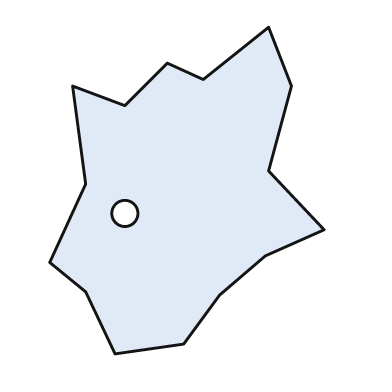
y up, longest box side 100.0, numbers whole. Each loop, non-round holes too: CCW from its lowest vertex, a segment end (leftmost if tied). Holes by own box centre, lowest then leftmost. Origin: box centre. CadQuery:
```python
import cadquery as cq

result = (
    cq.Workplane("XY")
    .moveTo(-22.0, -50.0)
    .lineTo(-1.0, -47.0)
    .lineTo(10.0, -32.0)
    .lineTo(24.0, -20.0)
    .lineTo(42.0, -12.0)
    .lineTo(25.0, 6.0)
    .lineTo(32.0, 32.0)
    .lineTo(25.0, 50.0)
    .lineTo(5.0, 34.0)
    .lineTo(-6.0, 39.0)
    .lineTo(-19.0, 26.0)
    .lineTo(-35.0, 32.0)
    .lineTo(-31.0, 2.0)
    .lineTo(-42.0, -22.0)
    .lineTo(-31.0, -31.0)
    .close()
    .moveTo(-19.0, -7.0)
    .circle(4.0)
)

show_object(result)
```